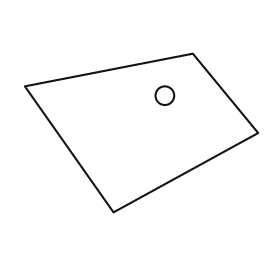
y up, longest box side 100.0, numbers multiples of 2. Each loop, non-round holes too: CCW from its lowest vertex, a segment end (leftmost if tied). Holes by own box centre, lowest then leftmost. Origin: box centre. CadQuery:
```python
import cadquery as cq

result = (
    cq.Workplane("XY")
    .moveTo(-12.0, -34.0)
    .lineTo(50.0, 0.0)
    .lineTo(22.0, 34.0)
    .lineTo(-50.0, 20.0)
    .close()
    .moveTo(10.0, 16.0)
    .circle(4.0)
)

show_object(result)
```